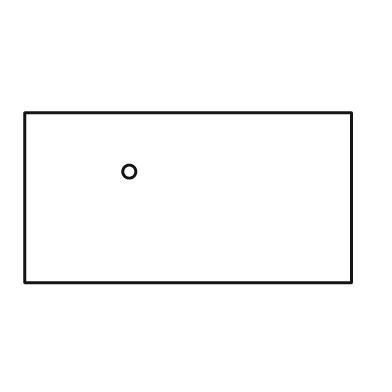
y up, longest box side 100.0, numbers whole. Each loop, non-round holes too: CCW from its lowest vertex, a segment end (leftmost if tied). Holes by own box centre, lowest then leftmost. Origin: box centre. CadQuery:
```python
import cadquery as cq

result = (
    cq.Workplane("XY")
    .moveTo(-50.0, -26.0)
    .lineTo(50.0, -26.0)
    .lineTo(50.0, 26.0)
    .lineTo(-50.0, 26.0)
    .close()
    .moveTo(-18.0, 8.0)
    .circle(2.0)
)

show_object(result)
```